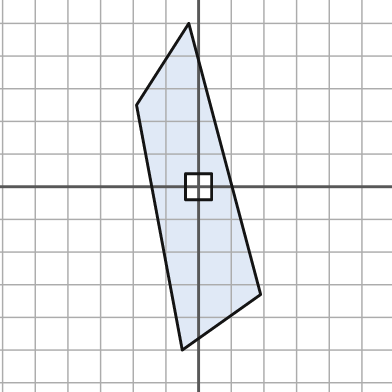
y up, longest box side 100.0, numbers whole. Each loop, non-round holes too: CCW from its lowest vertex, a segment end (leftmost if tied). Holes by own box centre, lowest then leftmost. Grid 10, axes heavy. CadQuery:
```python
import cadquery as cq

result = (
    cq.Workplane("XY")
    .moveTo(-5.0, -50.0)
    .lineTo(19.0, -33.0)
    .lineTo(-3.0, 50.0)
    .lineTo(-19.0, 25.0)
    .close()
    .moveTo(-4.0, -4.0)
    .lineTo(4.0, -4.0)
    .lineTo(4.0, 4.0)
    .lineTo(-4.0, 4.0)
    .close()
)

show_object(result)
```